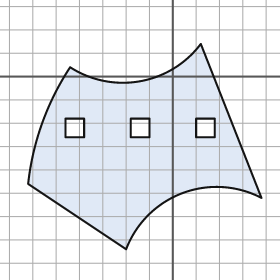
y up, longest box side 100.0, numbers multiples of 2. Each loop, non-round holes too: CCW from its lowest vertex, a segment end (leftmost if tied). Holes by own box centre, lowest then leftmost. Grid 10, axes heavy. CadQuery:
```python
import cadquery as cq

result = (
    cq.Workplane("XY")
    .moveTo(-20.0, -74.0)
    .threePointArc((4.0, -50.0), (38.0, -52.0))
    .lineTo(12.0, 14.0)
    .threePointArc((-14.0, -2.0), (-44.0, 4.0))
    .threePointArc((-56.0, -20.0), (-62.0, -46.0))
    .close()
    .moveTo(-46.0, -26.0)
    .lineTo(-38.0, -26.0)
    .lineTo(-38.0, -18.0)
    .lineTo(-46.0, -18.0)
    .close()
    .moveTo(-18.0, -26.0)
    .lineTo(-10.0, -26.0)
    .lineTo(-10.0, -18.0)
    .lineTo(-18.0, -18.0)
    .close()
    .moveTo(10.0, -26.0)
    .lineTo(18.0, -26.0)
    .lineTo(18.0, -18.0)
    .lineTo(10.0, -18.0)
    .close()
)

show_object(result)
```